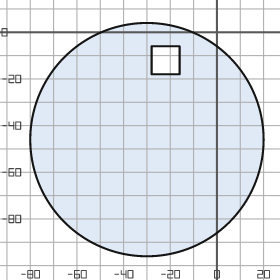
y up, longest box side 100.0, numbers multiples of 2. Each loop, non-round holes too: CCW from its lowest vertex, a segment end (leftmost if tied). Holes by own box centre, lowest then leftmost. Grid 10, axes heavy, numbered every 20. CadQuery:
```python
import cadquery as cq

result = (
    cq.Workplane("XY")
    .moveTo(-30.0, -46.0)
    .circle(50.0)
    .moveTo(-28.0, -18.0)
    .lineTo(-16.0, -18.0)
    .lineTo(-16.0, -6.0)
    .lineTo(-28.0, -6.0)
    .close()
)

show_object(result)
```